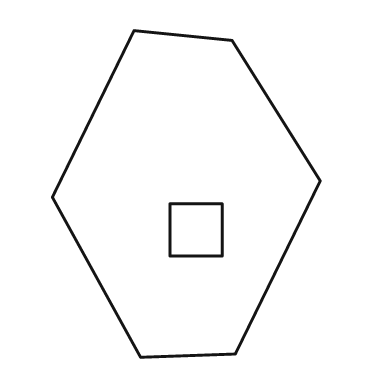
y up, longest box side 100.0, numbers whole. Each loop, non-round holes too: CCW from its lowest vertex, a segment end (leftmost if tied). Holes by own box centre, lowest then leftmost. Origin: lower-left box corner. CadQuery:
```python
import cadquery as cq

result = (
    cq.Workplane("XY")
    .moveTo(27.0, 0.0)
    .lineTo(56.0, 1.0)
    .lineTo(82.0, 54.0)
    .lineTo(55.0, 97.0)
    .lineTo(25.0, 100.0)
    .lineTo(0.0, 49.0)
    .close()
    .moveTo(36.0, 31.0)
    .lineTo(52.0, 31.0)
    .lineTo(52.0, 47.0)
    .lineTo(36.0, 47.0)
    .close()
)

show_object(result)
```